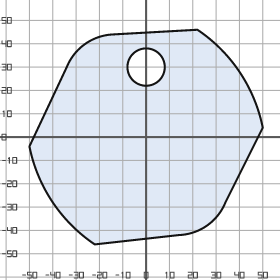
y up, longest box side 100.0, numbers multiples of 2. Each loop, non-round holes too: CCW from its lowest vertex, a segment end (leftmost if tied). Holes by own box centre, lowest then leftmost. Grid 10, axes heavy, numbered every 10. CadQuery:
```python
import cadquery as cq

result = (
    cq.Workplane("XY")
    .moveTo(-22.0, -46.0)
    .lineTo(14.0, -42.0)
    .threePointArc((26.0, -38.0), (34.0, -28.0))
    .lineTo(50.0, 4.0)
    .threePointArc((40.0, 28.0), (22.0, 46.0))
    .lineTo(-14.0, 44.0)
    .threePointArc((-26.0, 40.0), (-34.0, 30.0))
    .lineTo(-50.0, -4.0)
    .threePointArc((-40.0, -28.0), (-22.0, -46.0))
    .close()
    .moveTo(0.0, 30.0)
    .circle(8.0)
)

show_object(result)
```